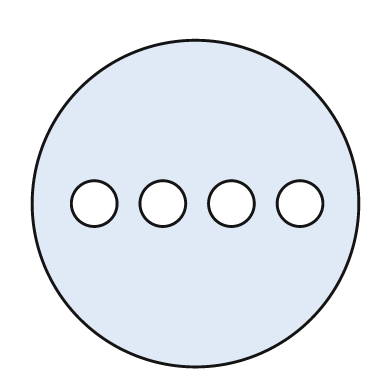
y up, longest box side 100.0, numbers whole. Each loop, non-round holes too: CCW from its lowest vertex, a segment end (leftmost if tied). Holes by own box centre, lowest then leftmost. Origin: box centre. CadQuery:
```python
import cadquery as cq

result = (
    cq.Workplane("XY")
    .moveTo(0.0, 0.0)
    .circle(50.0)
    .moveTo(-31.0, 0.0)
    .circle(7.0)
    .moveTo(-10.0, 0.0)
    .circle(7.0)
    .moveTo(11.0, 0.0)
    .circle(7.0)
    .moveTo(32.0, 0.0)
    .circle(7.0)
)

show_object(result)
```